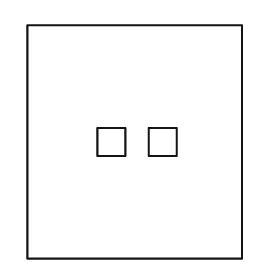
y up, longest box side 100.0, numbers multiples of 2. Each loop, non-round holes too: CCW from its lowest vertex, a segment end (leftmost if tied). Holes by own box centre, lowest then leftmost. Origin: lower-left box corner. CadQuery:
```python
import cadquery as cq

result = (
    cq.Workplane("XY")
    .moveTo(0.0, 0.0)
    .lineTo(92.0, 0.0)
    .lineTo(92.0, 100.0)
    .lineTo(0.0, 100.0)
    .close()
    .moveTo(30.0, 44.0)
    .lineTo(42.0, 44.0)
    .lineTo(42.0, 56.0)
    .lineTo(30.0, 56.0)
    .close()
    .moveTo(52.0, 44.0)
    .lineTo(64.0, 44.0)
    .lineTo(64.0, 56.0)
    .lineTo(52.0, 56.0)
    .close()
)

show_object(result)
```